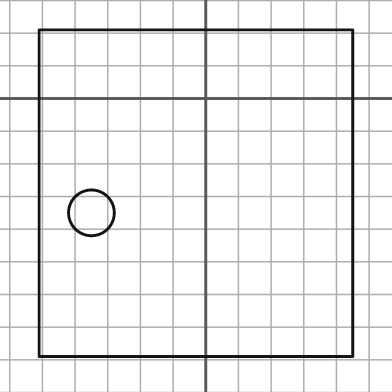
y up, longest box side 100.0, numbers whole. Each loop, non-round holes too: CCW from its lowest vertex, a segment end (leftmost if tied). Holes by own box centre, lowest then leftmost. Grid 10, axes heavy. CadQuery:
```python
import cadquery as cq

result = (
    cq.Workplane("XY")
    .moveTo(-51.0, -79.0)
    .lineTo(45.0, -79.0)
    .lineTo(45.0, 21.0)
    .lineTo(-51.0, 21.0)
    .close()
    .moveTo(-35.0, -35.0)
    .circle(7.0)
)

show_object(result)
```